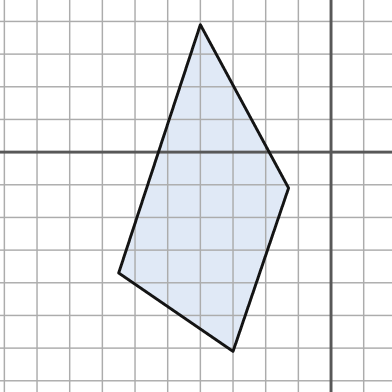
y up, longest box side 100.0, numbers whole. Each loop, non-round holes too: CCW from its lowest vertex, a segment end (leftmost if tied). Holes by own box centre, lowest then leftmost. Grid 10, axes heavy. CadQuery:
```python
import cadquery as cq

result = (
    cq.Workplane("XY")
    .moveTo(-30.0, -61.0)
    .lineTo(-13.0, -11.0)
    .lineTo(-40.0, 39.0)
    .lineTo(-65.0, -37.0)
    .close()
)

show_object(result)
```